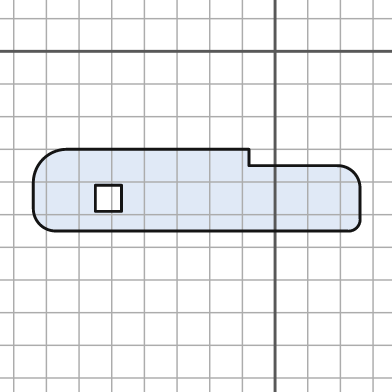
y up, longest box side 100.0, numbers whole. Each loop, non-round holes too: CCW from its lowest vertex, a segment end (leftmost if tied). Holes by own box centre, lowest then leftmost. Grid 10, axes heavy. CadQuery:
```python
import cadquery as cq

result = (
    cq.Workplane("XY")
    .moveTo(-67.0, -55.0)
    .lineTo(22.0, -55.0)
    .threePointArc((25.0, -54.0), (26.0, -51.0))
    .lineTo(26.0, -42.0)
    .threePointArc((24.0, -37.0), (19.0, -35.0))
    .lineTo(-8.0, -35.0)
    .lineTo(-8.0, -30.0)
    .lineTo(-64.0, -30.0)
    .threePointArc((-71.0, -33.0), (-74.0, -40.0))
    .lineTo(-74.0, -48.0)
    .threePointArc((-72.0, -53.0), (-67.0, -55.0))
    .close()
    .moveTo(-55.0, -49.0)
    .lineTo(-47.0, -49.0)
    .lineTo(-47.0, -41.0)
    .lineTo(-55.0, -41.0)
    .close()
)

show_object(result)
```